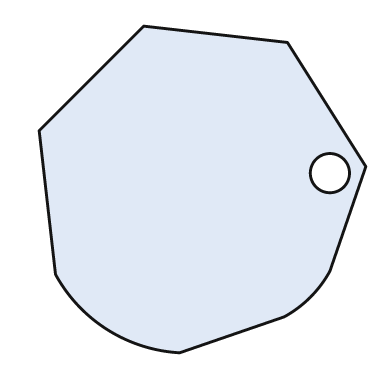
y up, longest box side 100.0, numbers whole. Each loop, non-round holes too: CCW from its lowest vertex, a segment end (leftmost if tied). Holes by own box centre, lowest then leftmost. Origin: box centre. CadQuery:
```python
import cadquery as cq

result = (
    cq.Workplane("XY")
    .moveTo(-7.0, -50.0)
    .lineTo(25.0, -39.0)
    .threePointArc((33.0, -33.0), (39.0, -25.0))
    .lineTo(50.0, 7.0)
    .lineTo(26.0, 45.0)
    .lineTo(-18.0, 50.0)
    .lineTo(-50.0, 18.0)
    .lineTo(-45.0, -26.0)
    .threePointArc((-29.0, -43.0), (-7.0, -50.0))
    .close()
    .moveTo(39.0, 5.0)
    .circle(6.0)
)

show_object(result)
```